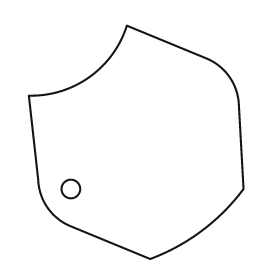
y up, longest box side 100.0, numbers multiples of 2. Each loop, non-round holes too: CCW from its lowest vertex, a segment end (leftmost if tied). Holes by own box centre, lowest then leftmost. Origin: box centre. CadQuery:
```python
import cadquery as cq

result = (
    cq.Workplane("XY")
    .moveTo(6.0, -50.0)
    .threePointArc((28.0, -38.0), (46.0, -20.0))
    .lineTo(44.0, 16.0)
    .threePointArc((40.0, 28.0), (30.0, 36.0))
    .lineTo(-4.0, 50.0)
    .threePointArc((-20.0, 28.0), (-46.0, 20.0))
    .lineTo(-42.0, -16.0)
    .threePointArc((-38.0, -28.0), (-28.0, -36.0))
    .close()
    .moveTo(-28.0, -20.0)
    .circle(4.0)
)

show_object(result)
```